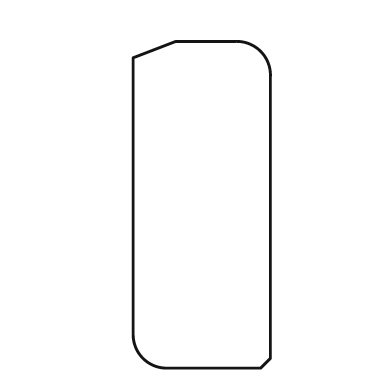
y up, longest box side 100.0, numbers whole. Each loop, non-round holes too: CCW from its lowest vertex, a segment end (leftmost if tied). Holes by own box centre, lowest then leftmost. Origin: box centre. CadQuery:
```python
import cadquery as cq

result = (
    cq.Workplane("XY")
    .moveTo(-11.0, -50.0)
    .lineTo(18.0, -50.0)
    .lineTo(21.0, -47.0)
    .lineTo(21.0, 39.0)
    .threePointArc((18.0, 47.0), (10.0, 50.0))
    .lineTo(-8.0, 50.0)
    .lineTo(-21.0, 45.0)
    .lineTo(-21.0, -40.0)
    .threePointArc((-18.0, -47.0), (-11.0, -50.0))
    .close()
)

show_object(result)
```